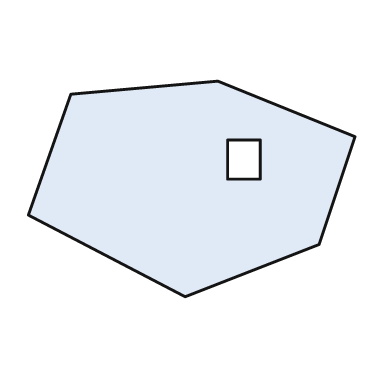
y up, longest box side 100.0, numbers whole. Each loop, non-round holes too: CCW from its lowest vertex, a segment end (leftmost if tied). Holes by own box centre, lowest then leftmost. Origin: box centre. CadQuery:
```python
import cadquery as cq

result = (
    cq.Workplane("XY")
    .moveTo(-2.0, -33.0)
    .lineTo(39.0, -17.0)
    .lineTo(50.0, 16.0)
    .lineTo(8.0, 33.0)
    .lineTo(-37.0, 29.0)
    .lineTo(-50.0, -8.0)
    .close()
    .moveTo(11.0, 3.0)
    .lineTo(21.0, 3.0)
    .lineTo(21.0, 15.0)
    .lineTo(11.0, 15.0)
    .close()
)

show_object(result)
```